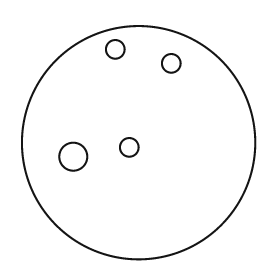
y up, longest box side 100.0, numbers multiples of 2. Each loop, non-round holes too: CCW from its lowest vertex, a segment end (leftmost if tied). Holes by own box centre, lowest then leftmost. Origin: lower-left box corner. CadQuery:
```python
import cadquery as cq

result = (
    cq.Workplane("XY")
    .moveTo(50.0, 50.0)
    .circle(50.0)
    .moveTo(22.0, 44.0)
    .circle(6.0)
    .moveTo(46.0, 48.0)
    .circle(4.0)
    .moveTo(64.0, 84.0)
    .circle(4.0)
    .moveTo(40.0, 90.0)
    .circle(4.0)
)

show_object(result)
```